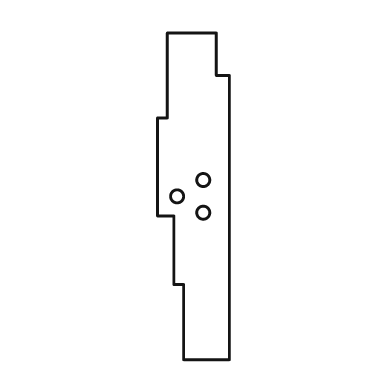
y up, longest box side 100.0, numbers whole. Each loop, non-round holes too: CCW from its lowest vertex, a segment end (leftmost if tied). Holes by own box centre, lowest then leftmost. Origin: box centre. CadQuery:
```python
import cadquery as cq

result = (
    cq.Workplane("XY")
    .moveTo(-3.0, -50.0)
    .lineTo(11.0, -50.0)
    .lineTo(11.0, 37.0)
    .lineTo(7.0, 37.0)
    .lineTo(7.0, 50.0)
    .lineTo(-8.0, 50.0)
    .lineTo(-8.0, 24.0)
    .lineTo(-11.0, 24.0)
    .lineTo(-11.0, -6.0)
    .lineTo(-6.0, -6.0)
    .lineTo(-6.0, -27.0)
    .lineTo(-3.0, -27.0)
    .close()
    .moveTo(3.0, -5.0)
    .circle(2.0)
    .moveTo(-5.0, 0.0)
    .circle(2.0)
    .moveTo(3.0, 5.0)
    .circle(2.0)
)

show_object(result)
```